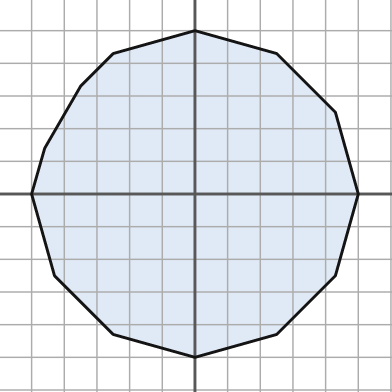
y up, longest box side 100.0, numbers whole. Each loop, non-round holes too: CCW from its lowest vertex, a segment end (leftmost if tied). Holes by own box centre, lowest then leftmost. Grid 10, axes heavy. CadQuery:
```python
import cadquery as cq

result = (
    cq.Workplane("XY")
    .moveTo(0.0, -50.0)
    .lineTo(25.0, -43.0)
    .lineTo(43.0, -25.0)
    .lineTo(50.0, 0.0)
    .lineTo(43.0, 25.0)
    .lineTo(25.0, 43.0)
    .lineTo(0.0, 50.0)
    .lineTo(-25.0, 43.0)
    .lineTo(-35.0, 33.0)
    .lineTo(-46.0, 14.0)
    .lineTo(-50.0, 0.0)
    .lineTo(-43.0, -25.0)
    .lineTo(-25.0, -43.0)
    .close()
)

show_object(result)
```